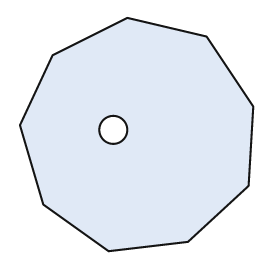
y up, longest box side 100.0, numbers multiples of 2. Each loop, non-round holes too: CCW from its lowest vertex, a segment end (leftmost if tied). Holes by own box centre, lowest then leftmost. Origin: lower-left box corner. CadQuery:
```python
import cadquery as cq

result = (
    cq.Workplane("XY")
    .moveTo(38.0, 0.0)
    .lineTo(72.0, 4.0)
    .lineTo(98.0, 28.0)
    .lineTo(100.0, 62.0)
    .lineTo(80.0, 92.0)
    .lineTo(46.0, 100.0)
    .lineTo(14.0, 84.0)
    .lineTo(0.0, 54.0)
    .lineTo(10.0, 20.0)
    .close()
    .moveTo(40.0, 52.0)
    .circle(6.0)
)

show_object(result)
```